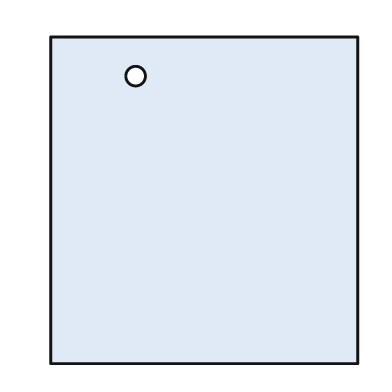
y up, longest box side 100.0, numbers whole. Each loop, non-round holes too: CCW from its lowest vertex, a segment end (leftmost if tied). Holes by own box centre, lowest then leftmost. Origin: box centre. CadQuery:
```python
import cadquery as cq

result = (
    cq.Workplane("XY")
    .moveTo(-47.0, -50.0)
    .lineTo(47.0, -50.0)
    .lineTo(47.0, 50.0)
    .lineTo(-47.0, 50.0)
    .close()
    .moveTo(-21.0, 38.0)
    .circle(3.0)
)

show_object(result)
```